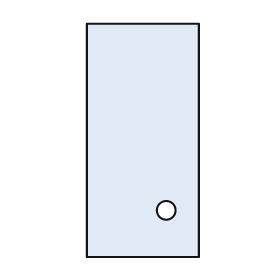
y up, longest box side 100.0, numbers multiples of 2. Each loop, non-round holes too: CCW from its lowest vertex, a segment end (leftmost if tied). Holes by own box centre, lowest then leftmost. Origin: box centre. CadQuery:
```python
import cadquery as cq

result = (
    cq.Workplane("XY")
    .moveTo(-24.0, -50.0)
    .lineTo(24.0, -50.0)
    .lineTo(24.0, 50.0)
    .lineTo(-24.0, 50.0)
    .close()
    .moveTo(10.0, -30.0)
    .circle(4.0)
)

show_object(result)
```